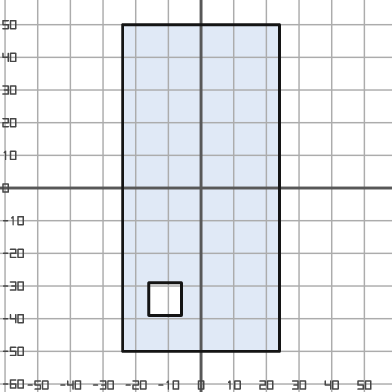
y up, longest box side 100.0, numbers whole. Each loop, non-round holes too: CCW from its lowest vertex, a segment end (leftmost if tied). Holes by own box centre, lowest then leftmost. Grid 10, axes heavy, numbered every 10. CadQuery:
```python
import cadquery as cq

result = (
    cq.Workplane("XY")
    .moveTo(-24.0, -50.0)
    .lineTo(24.0, -50.0)
    .lineTo(24.0, 50.0)
    .lineTo(-24.0, 50.0)
    .close()
    .moveTo(-16.0, -39.0)
    .lineTo(-6.0, -39.0)
    .lineTo(-6.0, -29.0)
    .lineTo(-16.0, -29.0)
    .close()
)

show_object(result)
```